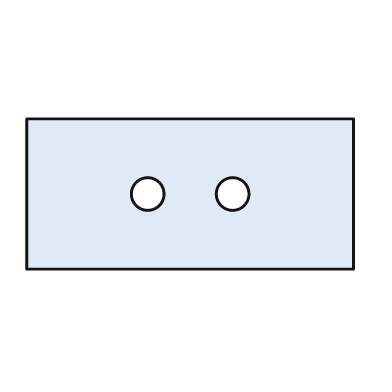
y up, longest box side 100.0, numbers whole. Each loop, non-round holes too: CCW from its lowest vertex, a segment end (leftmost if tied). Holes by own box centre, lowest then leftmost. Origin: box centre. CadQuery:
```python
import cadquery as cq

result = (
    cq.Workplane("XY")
    .moveTo(-50.0, -23.0)
    .lineTo(50.0, -23.0)
    .lineTo(50.0, 23.0)
    .lineTo(-50.0, 23.0)
    .close()
    .moveTo(-13.0, 0.0)
    .circle(5.0)
    .moveTo(13.0, 0.0)
    .circle(5.0)
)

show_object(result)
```